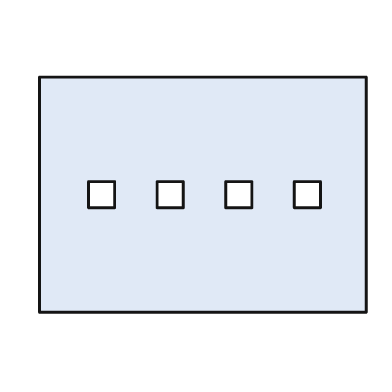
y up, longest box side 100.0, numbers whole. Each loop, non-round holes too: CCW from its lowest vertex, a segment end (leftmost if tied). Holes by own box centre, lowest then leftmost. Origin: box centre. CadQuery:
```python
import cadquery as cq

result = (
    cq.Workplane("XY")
    .moveTo(-50.0, -36.0)
    .lineTo(50.0, -36.0)
    .lineTo(50.0, 36.0)
    .lineTo(-50.0, 36.0)
    .close()
    .moveTo(-35.0, -4.0)
    .lineTo(-27.0, -4.0)
    .lineTo(-27.0, 4.0)
    .lineTo(-35.0, 4.0)
    .close()
    .moveTo(-14.0, -4.0)
    .lineTo(-6.0, -4.0)
    .lineTo(-6.0, 4.0)
    .lineTo(-14.0, 4.0)
    .close()
    .moveTo(7.0, -4.0)
    .lineTo(15.0, -4.0)
    .lineTo(15.0, 4.0)
    .lineTo(7.0, 4.0)
    .close()
    .moveTo(28.0, -4.0)
    .lineTo(36.0, -4.0)
    .lineTo(36.0, 4.0)
    .lineTo(28.0, 4.0)
    .close()
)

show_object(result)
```